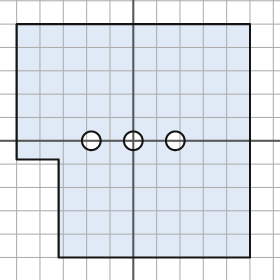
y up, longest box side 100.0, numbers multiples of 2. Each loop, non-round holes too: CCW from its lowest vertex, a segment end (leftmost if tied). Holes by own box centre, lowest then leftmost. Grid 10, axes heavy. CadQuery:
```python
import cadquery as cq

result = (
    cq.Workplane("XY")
    .moveTo(-32.0, -50.0)
    .lineTo(50.0, -50.0)
    .lineTo(50.0, 50.0)
    .lineTo(-50.0, 50.0)
    .lineTo(-50.0, -8.0)
    .lineTo(-32.0, -8.0)
    .close()
    .moveTo(-18.0, 0.0)
    .circle(4.0)
    .moveTo(0.0, 0.0)
    .circle(4.0)
    .moveTo(18.0, 0.0)
    .circle(4.0)
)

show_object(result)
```